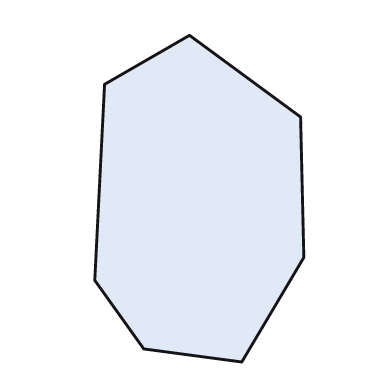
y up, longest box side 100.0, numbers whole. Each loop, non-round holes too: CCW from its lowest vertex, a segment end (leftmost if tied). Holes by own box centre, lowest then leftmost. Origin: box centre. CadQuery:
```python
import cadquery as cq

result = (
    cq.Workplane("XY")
    .moveTo(13.0, -50.0)
    .lineTo(32.0, -18.0)
    .lineTo(31.0, 25.0)
    .lineTo(-3.0, 50.0)
    .lineTo(-29.0, 35.0)
    .lineTo(-32.0, -25.0)
    .lineTo(-17.0, -46.0)
    .close()
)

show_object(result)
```